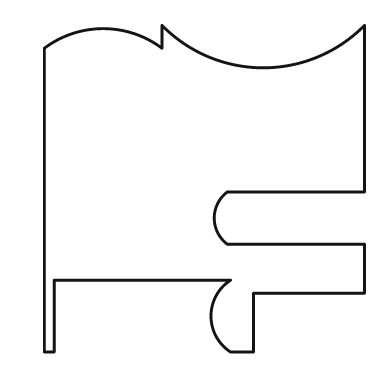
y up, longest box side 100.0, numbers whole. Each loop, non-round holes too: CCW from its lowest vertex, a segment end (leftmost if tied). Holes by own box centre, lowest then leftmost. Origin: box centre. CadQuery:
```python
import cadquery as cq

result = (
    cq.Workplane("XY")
    .moveTo(-49.0, -50.0)
    .lineTo(-46.0, -50.0)
    .lineTo(-46.0, -28.0)
    .lineTo(8.0, -28.0)
    .threePointArc((2.0, -39.0), (8.0, -50.0))
    .lineTo(15.0, -50.0)
    .lineTo(15.0, -32.0)
    .lineTo(49.0, -32.0)
    .lineTo(49.0, -17.0)
    .lineTo(7.0, -17.0)
    .threePointArc((3.0, -9.0), (7.0, -1.0))
    .lineTo(49.0, -1.0)
    .lineTo(49.0, 50.0)
    .threePointArc((18.0, 37.0), (-13.0, 50.0))
    .lineTo(-13.0, 43.0)
    .threePointArc((-31.0, 49.0), (-49.0, 43.0))
    .close()
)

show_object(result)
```